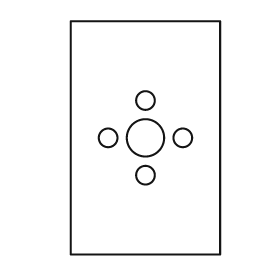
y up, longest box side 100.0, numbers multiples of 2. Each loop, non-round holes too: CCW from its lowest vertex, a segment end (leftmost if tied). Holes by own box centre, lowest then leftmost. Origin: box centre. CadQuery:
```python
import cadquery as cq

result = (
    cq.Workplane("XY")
    .moveTo(-32.0, -50.0)
    .lineTo(32.0, -50.0)
    .lineTo(32.0, 50.0)
    .lineTo(-32.0, 50.0)
    .close()
    .moveTo(0.0, -16.0)
    .circle(4.0)
    .moveTo(-16.0, 0.0)
    .circle(4.0)
    .moveTo(0.0, 0.0)
    .circle(8.0)
    .moveTo(16.0, 0.0)
    .circle(4.0)
    .moveTo(0.0, 16.0)
    .circle(4.0)
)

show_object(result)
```